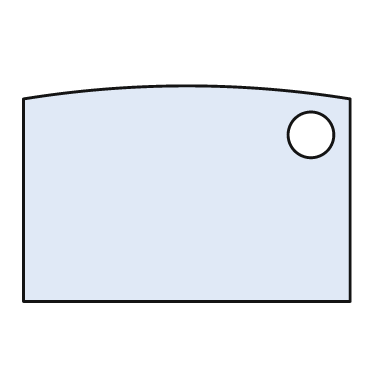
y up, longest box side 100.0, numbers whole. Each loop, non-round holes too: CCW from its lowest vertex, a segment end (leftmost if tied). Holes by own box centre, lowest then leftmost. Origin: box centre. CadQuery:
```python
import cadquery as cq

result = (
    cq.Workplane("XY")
    .moveTo(-50.0, -33.0)
    .lineTo(50.0, -33.0)
    .lineTo(50.0, 29.0)
    .threePointArc((0.0, 33.0), (-50.0, 29.0))
    .close()
    .moveTo(38.0, 18.0)
    .circle(7.0)
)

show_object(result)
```